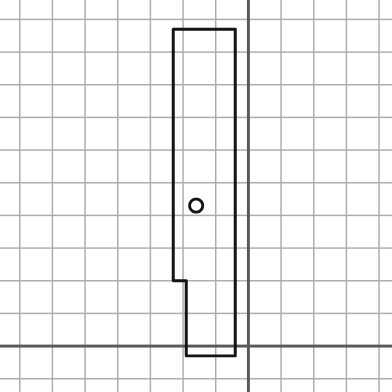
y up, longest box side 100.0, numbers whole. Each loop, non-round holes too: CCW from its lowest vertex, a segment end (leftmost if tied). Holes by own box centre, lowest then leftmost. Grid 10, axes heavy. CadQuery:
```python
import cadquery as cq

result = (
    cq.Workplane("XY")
    .moveTo(-19.0, -3.0)
    .lineTo(-4.0, -3.0)
    .lineTo(-4.0, 97.0)
    .lineTo(-23.0, 97.0)
    .lineTo(-23.0, 20.0)
    .lineTo(-19.0, 20.0)
    .close()
    .moveTo(-16.0, 43.0)
    .circle(2.0)
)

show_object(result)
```